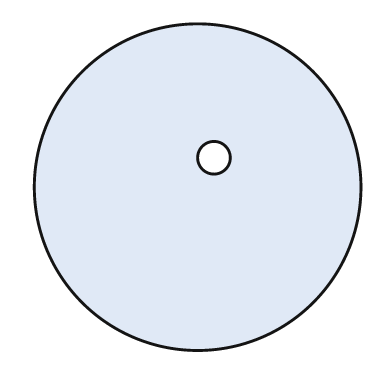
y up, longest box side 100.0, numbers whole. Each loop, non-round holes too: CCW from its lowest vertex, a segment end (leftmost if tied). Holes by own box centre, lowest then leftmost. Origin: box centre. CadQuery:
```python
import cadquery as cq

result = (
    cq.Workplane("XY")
    .moveTo(0.0, 0.0)
    .circle(50.0)
    .moveTo(5.0, 9.0)
    .circle(5.0)
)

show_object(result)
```